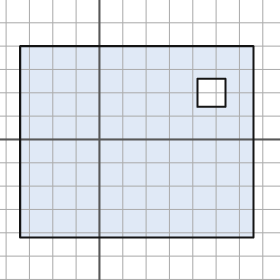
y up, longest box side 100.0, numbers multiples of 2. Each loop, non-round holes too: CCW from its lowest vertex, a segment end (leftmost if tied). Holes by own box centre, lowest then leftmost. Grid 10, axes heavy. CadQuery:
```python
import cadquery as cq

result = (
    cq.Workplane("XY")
    .moveTo(-34.0, -42.0)
    .lineTo(66.0, -42.0)
    .lineTo(66.0, 40.0)
    .lineTo(-34.0, 40.0)
    .close()
    .moveTo(42.0, 14.0)
    .lineTo(54.0, 14.0)
    .lineTo(54.0, 26.0)
    .lineTo(42.0, 26.0)
    .close()
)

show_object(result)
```